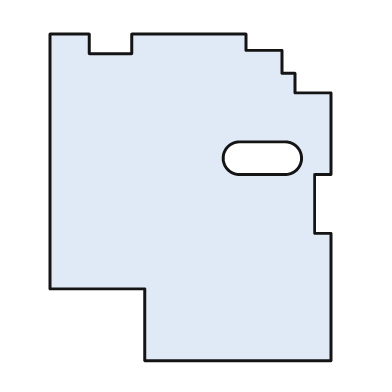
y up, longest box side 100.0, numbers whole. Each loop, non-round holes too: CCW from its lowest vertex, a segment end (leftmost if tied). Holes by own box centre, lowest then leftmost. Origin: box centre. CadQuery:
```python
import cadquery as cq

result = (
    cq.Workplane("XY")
    .moveTo(-14.0, -50.0)
    .lineTo(43.0, -50.0)
    .lineTo(43.0, -11.0)
    .lineTo(38.0, -11.0)
    .lineTo(38.0, 7.0)
    .lineTo(43.0, 7.0)
    .lineTo(43.0, 32.0)
    .lineTo(32.0, 32.0)
    .lineTo(32.0, 38.0)
    .lineTo(28.0, 38.0)
    .lineTo(28.0, 45.0)
    .lineTo(17.0, 45.0)
    .lineTo(17.0, 50.0)
    .lineTo(-18.0, 50.0)
    .lineTo(-18.0, 44.0)
    .lineTo(-31.0, 44.0)
    .lineTo(-31.0, 50.0)
    .lineTo(-43.0, 50.0)
    .lineTo(-43.0, -28.0)
    .lineTo(-14.0, -28.0)
    .close()
    .moveTo(15.0, 7.0)
    .lineTo(29.0, 7.0)
    .threePointArc((34.0, 12.0), (29.0, 17.0))
    .lineTo(15.0, 17.0)
    .threePointArc((10.0, 12.0), (15.0, 7.0))
    .close()
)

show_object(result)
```